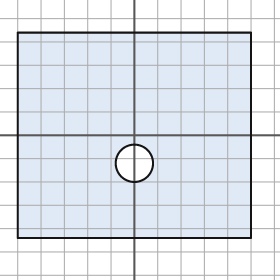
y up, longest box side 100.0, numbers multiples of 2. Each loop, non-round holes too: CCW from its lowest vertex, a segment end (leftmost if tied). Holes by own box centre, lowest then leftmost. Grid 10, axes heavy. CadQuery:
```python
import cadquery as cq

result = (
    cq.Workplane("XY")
    .moveTo(-50.0, -44.0)
    .lineTo(50.0, -44.0)
    .lineTo(50.0, 44.0)
    .lineTo(-50.0, 44.0)
    .close()
    .moveTo(0.0, -12.0)
    .circle(8.0)
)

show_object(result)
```